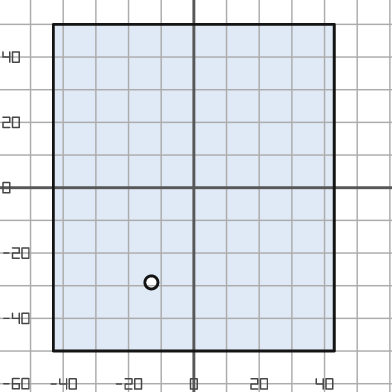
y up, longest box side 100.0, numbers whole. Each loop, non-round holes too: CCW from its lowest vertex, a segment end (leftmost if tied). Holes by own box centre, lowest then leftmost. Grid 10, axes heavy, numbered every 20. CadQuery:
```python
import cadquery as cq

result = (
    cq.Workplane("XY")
    .moveTo(-43.0, -50.0)
    .lineTo(43.0, -50.0)
    .lineTo(43.0, 50.0)
    .lineTo(-43.0, 50.0)
    .close()
    .moveTo(-13.0, -29.0)
    .circle(2.0)
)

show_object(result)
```